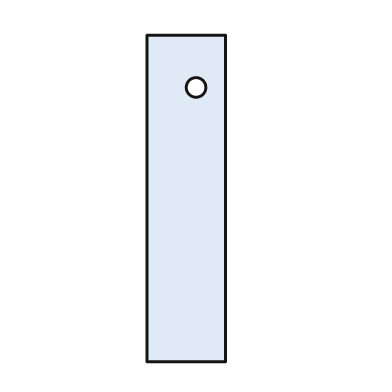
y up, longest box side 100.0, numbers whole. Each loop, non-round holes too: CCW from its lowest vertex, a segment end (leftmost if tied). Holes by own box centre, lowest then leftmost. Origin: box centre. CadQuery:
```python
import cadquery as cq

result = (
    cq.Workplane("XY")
    .moveTo(-12.0, -50.0)
    .lineTo(12.0, -50.0)
    .lineTo(12.0, 50.0)
    .lineTo(-12.0, 50.0)
    .close()
    .moveTo(3.0, 34.0)
    .circle(3.0)
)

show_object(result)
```